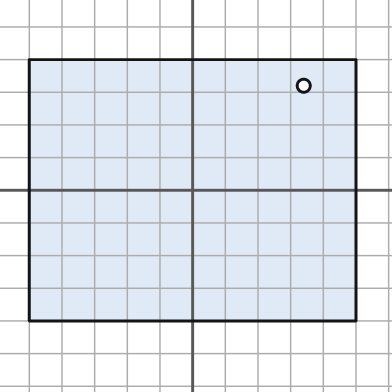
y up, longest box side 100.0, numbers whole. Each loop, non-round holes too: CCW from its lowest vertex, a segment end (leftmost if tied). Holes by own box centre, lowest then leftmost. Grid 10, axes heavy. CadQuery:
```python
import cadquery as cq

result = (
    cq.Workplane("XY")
    .moveTo(-50.0, -40.0)
    .lineTo(50.0, -40.0)
    .lineTo(50.0, 40.0)
    .lineTo(-50.0, 40.0)
    .close()
    .moveTo(34.0, 32.0)
    .circle(2.0)
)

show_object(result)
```